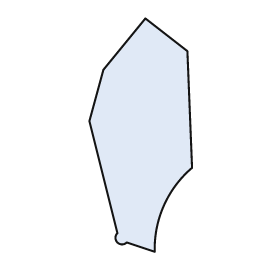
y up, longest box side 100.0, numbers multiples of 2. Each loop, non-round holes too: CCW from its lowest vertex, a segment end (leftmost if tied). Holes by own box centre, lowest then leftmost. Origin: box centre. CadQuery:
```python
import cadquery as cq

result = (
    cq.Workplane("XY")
    .moveTo(6.0, -50.0)
    .threePointArc((10.0, -30.0), (22.0, -14.0))
    .lineTo(20.0, 36.0)
    .lineTo(2.0, 50.0)
    .lineTo(-16.0, 28.0)
    .lineTo(-22.0, 6.0)
    .lineTo(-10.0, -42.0)
    .threePointArc((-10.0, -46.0), (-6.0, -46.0))
    .close()
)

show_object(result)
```